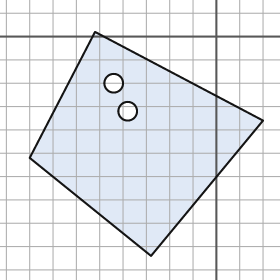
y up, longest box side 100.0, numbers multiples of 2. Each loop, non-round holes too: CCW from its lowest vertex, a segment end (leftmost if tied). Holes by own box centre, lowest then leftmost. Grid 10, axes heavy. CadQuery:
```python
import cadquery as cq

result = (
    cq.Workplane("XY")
    .moveTo(-28.0, -94.0)
    .lineTo(20.0, -36.0)
    .lineTo(-52.0, 2.0)
    .lineTo(-80.0, -52.0)
    .close()
    .moveTo(-38.0, -32.0)
    .circle(4.0)
    .moveTo(-44.0, -20.0)
    .circle(4.0)
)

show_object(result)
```